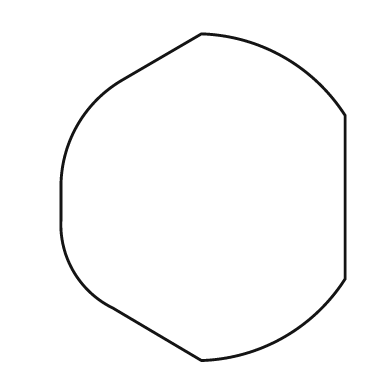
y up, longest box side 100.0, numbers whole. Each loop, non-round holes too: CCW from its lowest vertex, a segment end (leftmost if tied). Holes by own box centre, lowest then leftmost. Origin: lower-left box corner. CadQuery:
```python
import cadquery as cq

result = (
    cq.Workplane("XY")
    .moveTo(43.0, 0.0)
    .threePointArc((68.0, 7.0), (87.0, 25.0))
    .lineTo(87.0, 75.0)
    .threePointArc((68.0, 93.0), (43.0, 100.0))
    .lineTo(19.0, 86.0)
    .threePointArc((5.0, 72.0), (0.0, 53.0))
    .lineTo(0.0, 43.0)
    .threePointArc((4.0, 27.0), (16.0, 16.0))
    .close()
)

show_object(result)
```